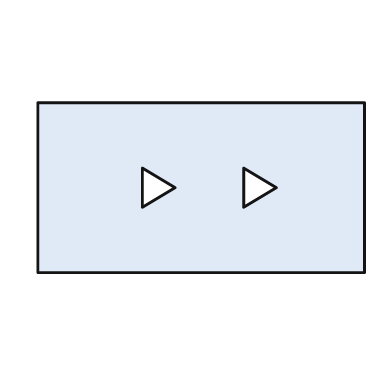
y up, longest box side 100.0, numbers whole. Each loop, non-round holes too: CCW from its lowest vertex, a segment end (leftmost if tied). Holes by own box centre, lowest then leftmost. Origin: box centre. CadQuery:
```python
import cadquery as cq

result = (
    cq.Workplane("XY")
    .moveTo(-50.0, -26.0)
    .lineTo(50.0, -26.0)
    .lineTo(50.0, 26.0)
    .lineTo(-50.0, 26.0)
    .close()
    .moveTo(-18.0, -6.0)
    .lineTo(-8.0, 0.0)
    .lineTo(-18.0, 6.0)
    .close()
    .moveTo(13.0, -6.0)
    .lineTo(23.0, 0.0)
    .lineTo(13.0, 6.0)
    .close()
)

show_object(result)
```